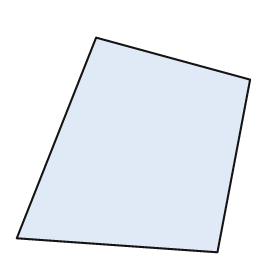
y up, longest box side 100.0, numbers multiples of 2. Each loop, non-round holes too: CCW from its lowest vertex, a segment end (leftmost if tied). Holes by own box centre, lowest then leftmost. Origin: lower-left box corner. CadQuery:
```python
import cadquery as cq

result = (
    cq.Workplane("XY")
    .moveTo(86.0, 0.0)
    .lineTo(100.0, 74.0)
    .lineTo(34.0, 92.0)
    .lineTo(0.0, 6.0)
    .close()
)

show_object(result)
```